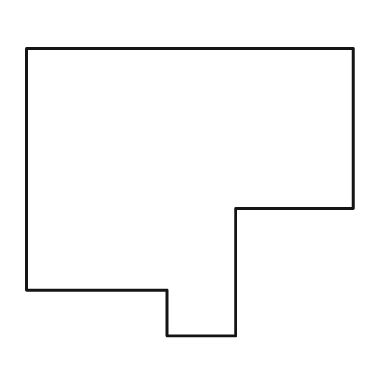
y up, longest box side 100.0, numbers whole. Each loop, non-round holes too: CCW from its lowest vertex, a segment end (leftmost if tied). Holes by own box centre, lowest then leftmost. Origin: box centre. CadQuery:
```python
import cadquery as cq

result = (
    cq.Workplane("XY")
    .moveTo(-7.0, -44.0)
    .lineTo(14.0, -44.0)
    .lineTo(14.0, -5.0)
    .lineTo(50.0, -5.0)
    .lineTo(50.0, 44.0)
    .lineTo(-50.0, 44.0)
    .lineTo(-50.0, -30.0)
    .lineTo(-7.0, -30.0)
    .close()
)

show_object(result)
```